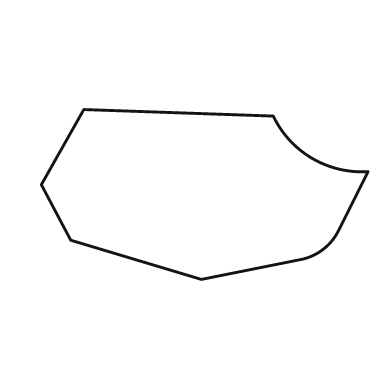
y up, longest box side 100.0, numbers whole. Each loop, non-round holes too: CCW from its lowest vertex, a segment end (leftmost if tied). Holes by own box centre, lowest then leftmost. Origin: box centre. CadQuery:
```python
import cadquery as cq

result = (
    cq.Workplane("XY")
    .moveTo(-1.0, -26.0)
    .lineTo(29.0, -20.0)
    .threePointArc((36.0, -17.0), (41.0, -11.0))
    .lineTo(50.0, 7.0)
    .threePointArc((33.0, 11.0), (21.0, 24.0))
    .lineTo(-37.0, 26.0)
    .lineTo(-50.0, 3.0)
    .lineTo(-41.0, -14.0)
    .close()
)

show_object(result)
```